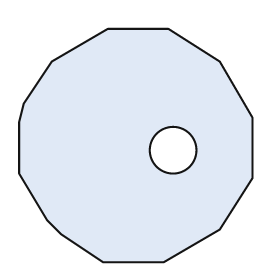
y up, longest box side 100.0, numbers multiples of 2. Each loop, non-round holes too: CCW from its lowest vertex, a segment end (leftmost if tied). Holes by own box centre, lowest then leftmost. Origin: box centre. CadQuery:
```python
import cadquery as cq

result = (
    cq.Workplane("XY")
    .moveTo(-14.0, -50.0)
    .lineTo(12.0, -50.0)
    .lineTo(36.0, -36.0)
    .lineTo(50.0, -14.0)
    .lineTo(50.0, 12.0)
    .lineTo(36.0, 36.0)
    .lineTo(14.0, 50.0)
    .lineTo(-12.0, 50.0)
    .lineTo(-36.0, 36.0)
    .lineTo(-48.0, 18.0)
    .lineTo(-50.0, 10.0)
    .lineTo(-50.0, -12.0)
    .lineTo(-38.0, -32.0)
    .lineTo(-32.0, -38.0)
    .close()
    .moveTo(16.0, -2.0)
    .circle(10.0)
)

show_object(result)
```